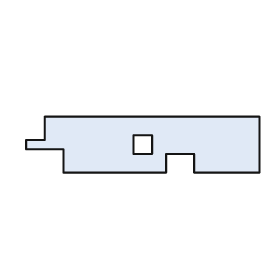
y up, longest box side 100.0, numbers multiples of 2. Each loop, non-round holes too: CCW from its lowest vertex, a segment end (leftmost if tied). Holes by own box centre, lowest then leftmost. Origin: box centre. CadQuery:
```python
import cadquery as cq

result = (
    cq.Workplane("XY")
    .moveTo(-34.0, -12.0)
    .lineTo(10.0, -12.0)
    .lineTo(10.0, -4.0)
    .lineTo(22.0, -4.0)
    .lineTo(22.0, -12.0)
    .lineTo(50.0, -12.0)
    .lineTo(50.0, 12.0)
    .lineTo(-42.0, 12.0)
    .lineTo(-42.0, 2.0)
    .lineTo(-50.0, 2.0)
    .lineTo(-50.0, -2.0)
    .lineTo(-34.0, -2.0)
    .close()
    .moveTo(-4.0, -4.0)
    .lineTo(4.0, -4.0)
    .lineTo(4.0, 4.0)
    .lineTo(-4.0, 4.0)
    .close()
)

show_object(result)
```